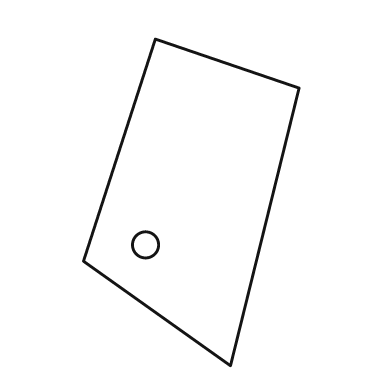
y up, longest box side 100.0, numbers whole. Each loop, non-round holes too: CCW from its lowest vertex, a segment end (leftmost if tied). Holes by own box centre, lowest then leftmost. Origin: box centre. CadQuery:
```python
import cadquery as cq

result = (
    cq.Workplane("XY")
    .moveTo(12.0, -50.0)
    .lineTo(33.0, 35.0)
    .lineTo(-11.0, 50.0)
    .lineTo(-33.0, -18.0)
    .close()
    .moveTo(-14.0, -13.0)
    .circle(4.0)
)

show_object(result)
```